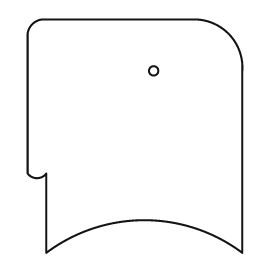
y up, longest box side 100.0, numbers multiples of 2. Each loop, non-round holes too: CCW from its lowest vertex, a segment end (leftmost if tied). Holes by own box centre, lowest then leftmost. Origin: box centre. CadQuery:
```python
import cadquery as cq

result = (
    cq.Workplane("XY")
    .moveTo(-38.0, -50.0)
    .threePointArc((4.0, -36.0), (46.0, -50.0))
    .lineTo(46.0, 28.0)
    .threePointArc((40.0, 44.0), (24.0, 50.0))
    .lineTo(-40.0, 50.0)
    .threePointArc((-44.0, 48.0), (-46.0, 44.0))
    .lineTo(-46.0, -16.0)
    .threePointArc((-42.0, -18.0), (-38.0, -16.0))
    .close()
    .moveTo(8.0, 28.0)
    .circle(2.0)
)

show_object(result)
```